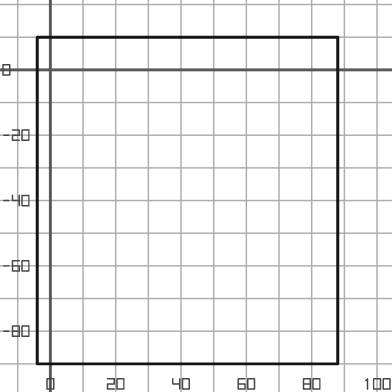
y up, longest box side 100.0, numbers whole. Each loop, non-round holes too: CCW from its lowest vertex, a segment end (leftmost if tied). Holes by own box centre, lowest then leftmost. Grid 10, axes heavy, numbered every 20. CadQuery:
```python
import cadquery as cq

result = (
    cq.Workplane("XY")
    .moveTo(-4.0, -90.0)
    .lineTo(88.0, -90.0)
    .lineTo(88.0, 10.0)
    .lineTo(-4.0, 10.0)
    .close()
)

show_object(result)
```